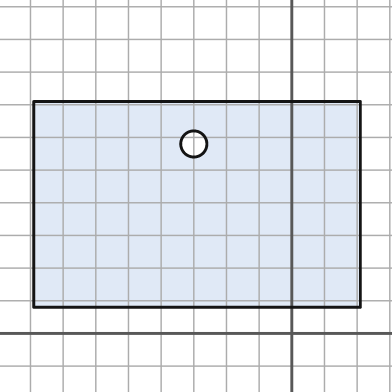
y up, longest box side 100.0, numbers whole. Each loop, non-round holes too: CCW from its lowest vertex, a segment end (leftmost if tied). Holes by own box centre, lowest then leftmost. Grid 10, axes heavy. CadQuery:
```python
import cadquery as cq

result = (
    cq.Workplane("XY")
    .moveTo(-79.0, 8.0)
    .lineTo(21.0, 8.0)
    .lineTo(21.0, 71.0)
    .lineTo(-79.0, 71.0)
    .close()
    .moveTo(-30.0, 58.0)
    .circle(4.0)
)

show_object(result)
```